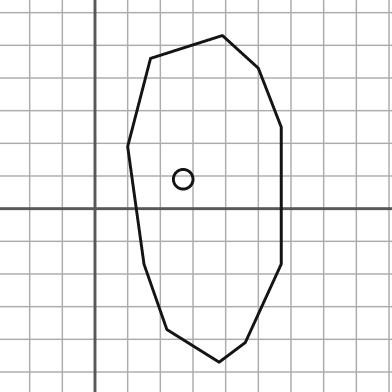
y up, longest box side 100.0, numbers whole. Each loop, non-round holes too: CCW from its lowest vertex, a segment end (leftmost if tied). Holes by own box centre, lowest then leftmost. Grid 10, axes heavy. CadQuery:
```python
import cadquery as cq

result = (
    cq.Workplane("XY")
    .moveTo(38.0, -47.0)
    .lineTo(46.0, -41.0)
    .lineTo(57.0, -17.0)
    .lineTo(57.0, 25.0)
    .lineTo(50.0, 43.0)
    .lineTo(39.0, 53.0)
    .lineTo(17.0, 46.0)
    .lineTo(10.0, 19.0)
    .lineTo(15.0, -17.0)
    .lineTo(22.0, -37.0)
    .close()
    .moveTo(27.0, 9.0)
    .circle(3.0)
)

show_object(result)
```